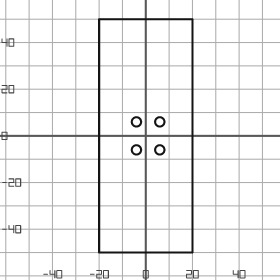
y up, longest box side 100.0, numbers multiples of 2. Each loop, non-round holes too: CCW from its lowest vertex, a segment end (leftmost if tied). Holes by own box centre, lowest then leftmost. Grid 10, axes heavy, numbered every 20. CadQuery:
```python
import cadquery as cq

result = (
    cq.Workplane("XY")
    .moveTo(-20.0, -50.0)
    .lineTo(20.0, -50.0)
    .lineTo(20.0, 50.0)
    .lineTo(-20.0, 50.0)
    .close()
    .moveTo(-4.0, -6.0)
    .circle(2.0)
    .moveTo(6.0, -6.0)
    .circle(2.0)
    .moveTo(-4.0, 6.0)
    .circle(2.0)
    .moveTo(6.0, 6.0)
    .circle(2.0)
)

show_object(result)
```